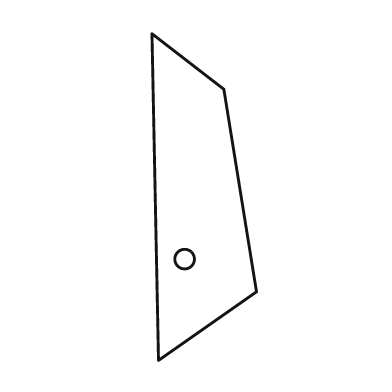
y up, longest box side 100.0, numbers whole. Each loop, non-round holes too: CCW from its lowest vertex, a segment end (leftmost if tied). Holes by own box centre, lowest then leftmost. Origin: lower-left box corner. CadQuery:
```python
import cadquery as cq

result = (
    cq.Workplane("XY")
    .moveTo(2.0, 0.0)
    .lineTo(32.0, 21.0)
    .lineTo(22.0, 83.0)
    .lineTo(0.0, 100.0)
    .close()
    .moveTo(10.0, 31.0)
    .circle(3.0)
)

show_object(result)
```